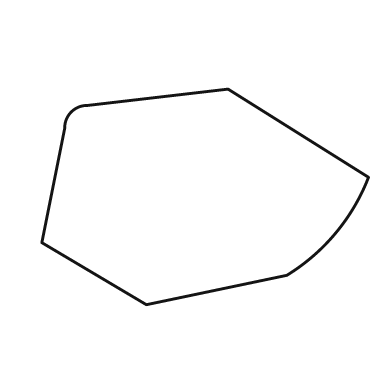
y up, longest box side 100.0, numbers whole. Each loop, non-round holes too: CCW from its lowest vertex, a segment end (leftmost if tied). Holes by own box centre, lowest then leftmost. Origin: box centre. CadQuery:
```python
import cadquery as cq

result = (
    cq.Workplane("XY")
    .moveTo(-18.0, -33.0)
    .lineTo(25.0, -24.0)
    .threePointArc((40.0, -11.0), (50.0, 6.0))
    .lineTo(7.0, 33.0)
    .lineTo(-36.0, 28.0)
    .threePointArc((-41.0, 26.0), (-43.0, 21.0))
    .lineTo(-50.0, -14.0)
    .close()
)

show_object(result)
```